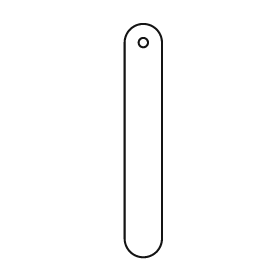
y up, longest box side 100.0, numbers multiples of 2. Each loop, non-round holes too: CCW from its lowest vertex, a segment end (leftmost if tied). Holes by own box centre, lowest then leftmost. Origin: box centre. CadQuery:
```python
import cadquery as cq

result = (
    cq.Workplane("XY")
    .moveTo(-8.0, -42.0)
    .threePointArc((0.0, -50.0), (8.0, -42.0))
    .lineTo(8.0, 42.0)
    .threePointArc((0.0, 50.0), (-8.0, 42.0))
    .close()
    .moveTo(0.0, 42.0)
    .circle(2.0)
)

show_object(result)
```